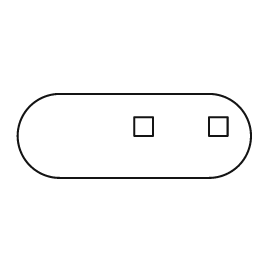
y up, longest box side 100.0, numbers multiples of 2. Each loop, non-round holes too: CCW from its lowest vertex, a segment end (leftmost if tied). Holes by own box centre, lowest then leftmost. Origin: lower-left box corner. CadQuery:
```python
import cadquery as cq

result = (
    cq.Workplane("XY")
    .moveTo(18.0, 0.0)
    .lineTo(82.0, 0.0)
    .threePointArc((100.0, 18.0), (82.0, 36.0))
    .lineTo(18.0, 36.0)
    .threePointArc((0.0, 18.0), (18.0, 0.0))
    .close()
    .moveTo(50.0, 18.0)
    .lineTo(58.0, 18.0)
    .lineTo(58.0, 26.0)
    .lineTo(50.0, 26.0)
    .close()
    .moveTo(82.0, 18.0)
    .lineTo(90.0, 18.0)
    .lineTo(90.0, 26.0)
    .lineTo(82.0, 26.0)
    .close()
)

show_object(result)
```